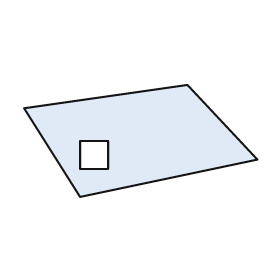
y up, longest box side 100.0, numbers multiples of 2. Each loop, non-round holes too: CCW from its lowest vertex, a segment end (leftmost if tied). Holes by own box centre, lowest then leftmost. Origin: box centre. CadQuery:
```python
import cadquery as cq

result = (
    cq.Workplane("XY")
    .moveTo(-26.0, -24.0)
    .lineTo(50.0, -8.0)
    .lineTo(20.0, 24.0)
    .lineTo(-50.0, 14.0)
    .close()
    .moveTo(-26.0, -12.0)
    .lineTo(-14.0, -12.0)
    .lineTo(-14.0, 0.0)
    .lineTo(-26.0, 0.0)
    .close()
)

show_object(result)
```